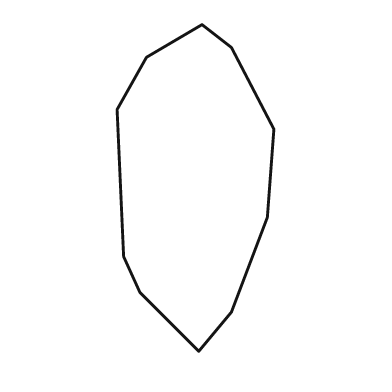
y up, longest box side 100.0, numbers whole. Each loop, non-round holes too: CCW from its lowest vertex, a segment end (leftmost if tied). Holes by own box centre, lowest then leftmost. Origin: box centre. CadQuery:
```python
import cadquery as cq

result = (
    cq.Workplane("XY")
    .moveTo(1.0, -50.0)
    .lineTo(11.0, -38.0)
    .lineTo(22.0, -9.0)
    .lineTo(24.0, 18.0)
    .lineTo(11.0, 43.0)
    .lineTo(2.0, 50.0)
    .lineTo(-15.0, 40.0)
    .lineTo(-24.0, 24.0)
    .lineTo(-22.0, -21.0)
    .lineTo(-17.0, -32.0)
    .close()
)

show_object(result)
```